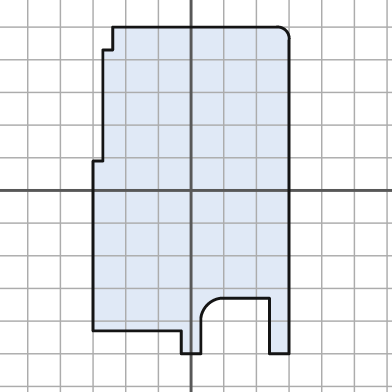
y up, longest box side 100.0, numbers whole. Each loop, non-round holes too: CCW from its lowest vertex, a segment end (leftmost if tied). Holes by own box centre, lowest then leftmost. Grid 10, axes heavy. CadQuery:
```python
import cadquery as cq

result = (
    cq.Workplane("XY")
    .moveTo(-3.0, -50.0)
    .lineTo(3.0, -50.0)
    .lineTo(3.0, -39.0)
    .threePointArc((5.0, -35.0), (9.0, -33.0))
    .lineTo(24.0, -33.0)
    .lineTo(24.0, -50.0)
    .lineTo(30.0, -50.0)
    .lineTo(30.0, 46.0)
    .threePointArc((29.0, 49.0), (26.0, 50.0))
    .lineTo(-24.0, 50.0)
    .lineTo(-24.0, 43.0)
    .lineTo(-27.0, 43.0)
    .lineTo(-27.0, 9.0)
    .lineTo(-30.0, 9.0)
    .lineTo(-30.0, -43.0)
    .lineTo(-3.0, -43.0)
    .close()
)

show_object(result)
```